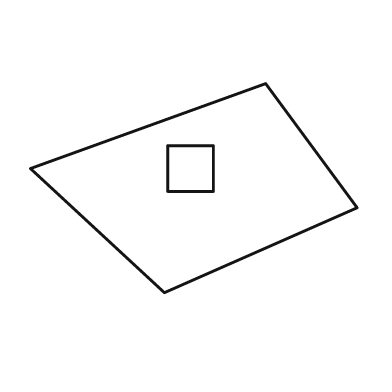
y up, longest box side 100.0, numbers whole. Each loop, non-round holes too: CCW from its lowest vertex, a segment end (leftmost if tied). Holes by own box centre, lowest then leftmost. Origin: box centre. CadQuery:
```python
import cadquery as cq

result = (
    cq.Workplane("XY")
    .moveTo(-9.0, -32.0)
    .lineTo(50.0, -6.0)
    .lineTo(22.0, 32.0)
    .lineTo(-50.0, 6.0)
    .close()
    .moveTo(-8.0, -1.0)
    .lineTo(6.0, -1.0)
    .lineTo(6.0, 13.0)
    .lineTo(-8.0, 13.0)
    .close()
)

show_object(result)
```